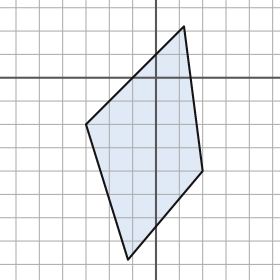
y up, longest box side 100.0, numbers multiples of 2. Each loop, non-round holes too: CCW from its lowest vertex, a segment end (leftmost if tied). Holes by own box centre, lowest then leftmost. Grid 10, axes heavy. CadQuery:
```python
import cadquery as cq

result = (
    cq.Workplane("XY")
    .moveTo(-12.0, -78.0)
    .lineTo(20.0, -40.0)
    .lineTo(12.0, 22.0)
    .lineTo(-30.0, -20.0)
    .close()
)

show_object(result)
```